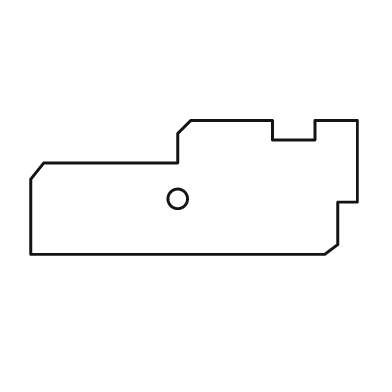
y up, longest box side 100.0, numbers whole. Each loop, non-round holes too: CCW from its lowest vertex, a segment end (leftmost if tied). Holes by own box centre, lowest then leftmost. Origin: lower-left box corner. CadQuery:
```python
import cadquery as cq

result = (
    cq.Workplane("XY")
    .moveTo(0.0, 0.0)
    .lineTo(90.0, 0.0)
    .lineTo(94.0, 3.0)
    .lineTo(94.0, 16.0)
    .lineTo(100.0, 16.0)
    .lineTo(100.0, 41.0)
    .lineTo(87.0, 41.0)
    .lineTo(87.0, 35.0)
    .lineTo(74.0, 35.0)
    .lineTo(74.0, 41.0)
    .lineTo(49.0, 41.0)
    .lineTo(45.0, 37.0)
    .lineTo(45.0, 28.0)
    .lineTo(4.0, 28.0)
    .lineTo(0.0, 23.0)
    .close()
    .moveTo(45.0, 17.0)
    .circle(3.0)
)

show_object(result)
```